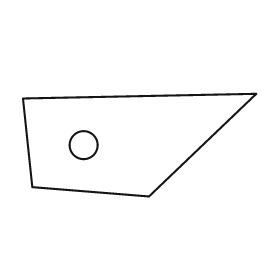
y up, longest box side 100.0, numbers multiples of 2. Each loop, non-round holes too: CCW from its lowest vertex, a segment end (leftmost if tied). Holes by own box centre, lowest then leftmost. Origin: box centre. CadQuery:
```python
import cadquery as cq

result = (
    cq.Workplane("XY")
    .moveTo(4.0, -22.0)
    .lineTo(50.0, 22.0)
    .lineTo(-50.0, 20.0)
    .lineTo(-46.0, -18.0)
    .close()
    .moveTo(-24.0, 0.0)
    .circle(6.0)
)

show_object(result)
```